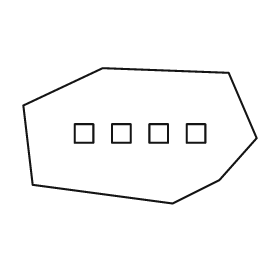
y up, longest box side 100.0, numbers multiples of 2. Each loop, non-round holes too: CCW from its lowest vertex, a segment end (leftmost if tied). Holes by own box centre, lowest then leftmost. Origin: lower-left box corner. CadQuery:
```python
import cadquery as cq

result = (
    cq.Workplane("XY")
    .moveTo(64.0, 0.0)
    .lineTo(84.0, 10.0)
    .lineTo(100.0, 28.0)
    .lineTo(88.0, 56.0)
    .lineTo(34.0, 58.0)
    .lineTo(0.0, 42.0)
    .lineTo(4.0, 8.0)
    .close()
    .moveTo(22.0, 26.0)
    .lineTo(30.0, 26.0)
    .lineTo(30.0, 34.0)
    .lineTo(22.0, 34.0)
    .close()
    .moveTo(38.0, 26.0)
    .lineTo(46.0, 26.0)
    .lineTo(46.0, 34.0)
    .lineTo(38.0, 34.0)
    .close()
    .moveTo(54.0, 26.0)
    .lineTo(62.0, 26.0)
    .lineTo(62.0, 34.0)
    .lineTo(54.0, 34.0)
    .close()
    .moveTo(70.0, 26.0)
    .lineTo(78.0, 26.0)
    .lineTo(78.0, 34.0)
    .lineTo(70.0, 34.0)
    .close()
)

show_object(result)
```